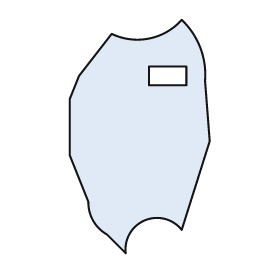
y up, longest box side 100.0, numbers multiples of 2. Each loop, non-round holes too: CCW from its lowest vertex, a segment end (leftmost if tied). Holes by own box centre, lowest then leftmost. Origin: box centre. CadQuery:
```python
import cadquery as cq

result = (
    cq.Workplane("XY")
    .moveTo(-6.0, -50.0)
    .threePointArc((2.0, -36.0), (18.0, -40.0))
    .lineTo(30.0, -2.0)
    .lineTo(28.0, 24.0)
    .threePointArc((26.0, 38.0), (18.0, 50.0))
    .threePointArc((4.0, 42.0), (-12.0, 44.0))
    .lineTo(-26.0, 26.0)
    .lineTo(-30.0, 16.0)
    .lineTo(-30.0, -8.0)
    .lineTo(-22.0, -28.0)
    .threePointArc((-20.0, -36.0), (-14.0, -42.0))
    .close()
    .moveTo(4.0, 22.0)
    .lineTo(20.0, 22.0)
    .lineTo(20.0, 30.0)
    .lineTo(4.0, 30.0)
    .close()
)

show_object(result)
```